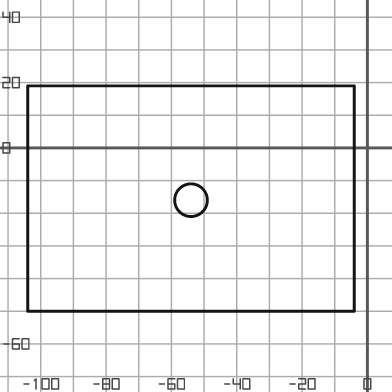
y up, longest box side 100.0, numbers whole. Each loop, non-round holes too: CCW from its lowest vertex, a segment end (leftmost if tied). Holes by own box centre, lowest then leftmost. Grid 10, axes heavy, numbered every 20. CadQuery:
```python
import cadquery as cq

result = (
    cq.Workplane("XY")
    .moveTo(-104.0, -50.0)
    .lineTo(-4.0, -50.0)
    .lineTo(-4.0, 19.0)
    .lineTo(-104.0, 19.0)
    .close()
    .moveTo(-54.0, -16.0)
    .circle(5.0)
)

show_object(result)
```